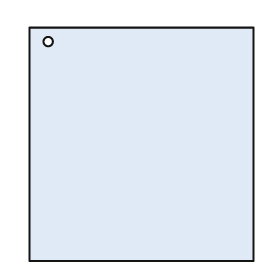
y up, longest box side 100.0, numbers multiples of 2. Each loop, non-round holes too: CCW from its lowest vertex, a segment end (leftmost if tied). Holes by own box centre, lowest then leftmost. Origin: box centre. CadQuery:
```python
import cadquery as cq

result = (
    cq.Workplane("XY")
    .moveTo(-48.0, -50.0)
    .lineTo(48.0, -50.0)
    .lineTo(48.0, 50.0)
    .lineTo(-48.0, 50.0)
    .close()
    .moveTo(-40.0, 44.0)
    .circle(2.0)
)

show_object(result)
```